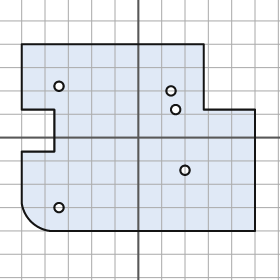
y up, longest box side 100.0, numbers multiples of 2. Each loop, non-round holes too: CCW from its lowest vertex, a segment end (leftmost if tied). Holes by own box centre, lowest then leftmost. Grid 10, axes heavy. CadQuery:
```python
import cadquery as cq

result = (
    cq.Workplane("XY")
    .moveTo(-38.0, -40.0)
    .lineTo(50.0, -40.0)
    .lineTo(50.0, 12.0)
    .lineTo(28.0, 12.0)
    .lineTo(28.0, 40.0)
    .lineTo(-50.0, 40.0)
    .lineTo(-50.0, 12.0)
    .lineTo(-36.0, 12.0)
    .lineTo(-36.0, -6.0)
    .lineTo(-50.0, -6.0)
    .lineTo(-50.0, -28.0)
    .threePointArc((-46.0, -36.0), (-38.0, -40.0))
    .close()
    .moveTo(-34.0, -30.0)
    .circle(2.0)
    .moveTo(20.0, -14.0)
    .circle(2.0)
    .moveTo(16.0, 12.0)
    .circle(2.0)
    .moveTo(14.0, 20.0)
    .circle(2.0)
    .moveTo(-34.0, 22.0)
    .circle(2.0)
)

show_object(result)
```